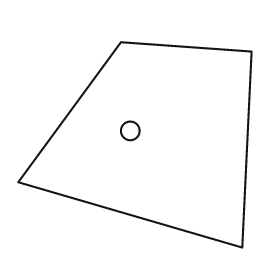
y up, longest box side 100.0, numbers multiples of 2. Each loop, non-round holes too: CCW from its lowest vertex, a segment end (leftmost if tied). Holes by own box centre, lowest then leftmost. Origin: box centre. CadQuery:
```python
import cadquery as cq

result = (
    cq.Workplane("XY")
    .moveTo(46.0, -44.0)
    .lineTo(50.0, 40.0)
    .lineTo(-6.0, 44.0)
    .lineTo(-50.0, -16.0)
    .close()
    .moveTo(-2.0, 6.0)
    .circle(4.0)
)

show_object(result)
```